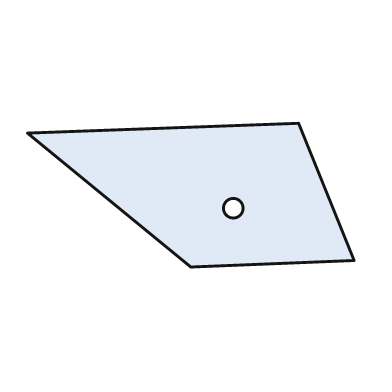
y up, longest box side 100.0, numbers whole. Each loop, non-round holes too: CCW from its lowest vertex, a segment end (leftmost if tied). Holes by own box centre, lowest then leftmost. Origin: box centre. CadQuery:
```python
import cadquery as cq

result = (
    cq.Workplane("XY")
    .moveTo(0.0, -22.0)
    .lineTo(50.0, -20.0)
    .lineTo(33.0, 22.0)
    .lineTo(-50.0, 19.0)
    .close()
    .moveTo(13.0, -4.0)
    .circle(3.0)
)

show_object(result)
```